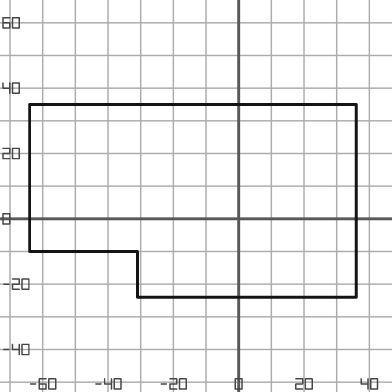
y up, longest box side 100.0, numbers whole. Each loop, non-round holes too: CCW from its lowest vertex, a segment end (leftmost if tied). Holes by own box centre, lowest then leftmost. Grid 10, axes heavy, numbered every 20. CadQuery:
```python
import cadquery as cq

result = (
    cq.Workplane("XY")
    .moveTo(-31.0, -24.0)
    .lineTo(36.0, -24.0)
    .lineTo(36.0, 35.0)
    .lineTo(-64.0, 35.0)
    .lineTo(-64.0, -10.0)
    .lineTo(-31.0, -10.0)
    .close()
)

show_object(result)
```